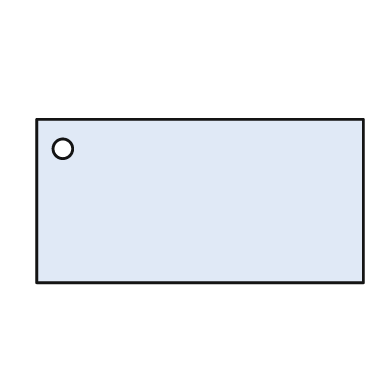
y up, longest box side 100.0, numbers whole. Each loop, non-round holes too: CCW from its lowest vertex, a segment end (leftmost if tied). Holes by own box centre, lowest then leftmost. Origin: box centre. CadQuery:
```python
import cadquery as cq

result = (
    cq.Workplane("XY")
    .moveTo(-50.0, -25.0)
    .lineTo(50.0, -25.0)
    .lineTo(50.0, 25.0)
    .lineTo(-50.0, 25.0)
    .close()
    .moveTo(-42.0, 16.0)
    .circle(3.0)
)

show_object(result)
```